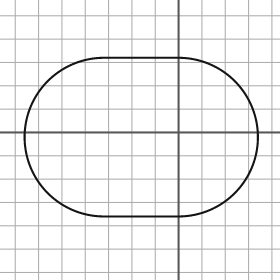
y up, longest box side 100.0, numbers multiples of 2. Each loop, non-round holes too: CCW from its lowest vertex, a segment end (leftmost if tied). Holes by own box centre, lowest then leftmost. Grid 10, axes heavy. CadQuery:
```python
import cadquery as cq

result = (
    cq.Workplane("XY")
    .moveTo(-32.0, -36.0)
    .lineTo(0.0, -36.0)
    .threePointArc((34.0, -2.0), (0.0, 32.0))
    .lineTo(-32.0, 32.0)
    .threePointArc((-66.0, -2.0), (-32.0, -36.0))
    .close()
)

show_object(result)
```